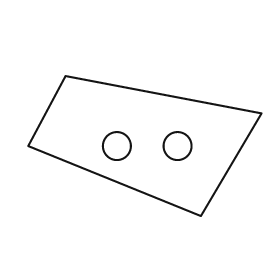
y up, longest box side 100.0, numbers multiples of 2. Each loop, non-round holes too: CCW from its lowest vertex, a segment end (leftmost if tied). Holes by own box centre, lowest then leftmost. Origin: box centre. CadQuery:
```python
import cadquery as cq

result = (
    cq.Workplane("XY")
    .moveTo(24.0, -30.0)
    .lineTo(50.0, 14.0)
    .lineTo(-34.0, 30.0)
    .lineTo(-50.0, 0.0)
    .close()
    .moveTo(-12.0, 0.0)
    .circle(6.0)
    .moveTo(14.0, 0.0)
    .circle(6.0)
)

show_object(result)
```